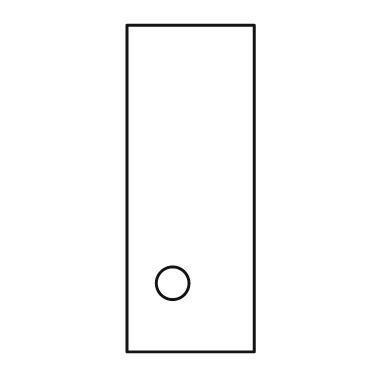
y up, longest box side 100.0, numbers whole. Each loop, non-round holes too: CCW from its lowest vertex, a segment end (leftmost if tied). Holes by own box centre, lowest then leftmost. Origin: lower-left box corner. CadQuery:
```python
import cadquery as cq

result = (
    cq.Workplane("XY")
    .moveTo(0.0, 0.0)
    .lineTo(39.0, 0.0)
    .lineTo(39.0, 100.0)
    .lineTo(0.0, 100.0)
    .close()
    .moveTo(14.0, 21.0)
    .circle(5.0)
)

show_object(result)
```